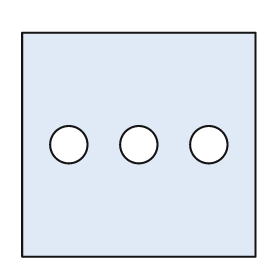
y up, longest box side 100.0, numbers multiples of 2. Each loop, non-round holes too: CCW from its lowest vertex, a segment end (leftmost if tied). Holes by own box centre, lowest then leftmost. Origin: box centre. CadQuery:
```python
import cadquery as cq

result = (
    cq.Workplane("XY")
    .moveTo(-50.0, -48.0)
    .lineTo(50.0, -48.0)
    .lineTo(50.0, 48.0)
    .lineTo(-50.0, 48.0)
    .close()
    .moveTo(-30.0, 0.0)
    .circle(8.0)
    .moveTo(0.0, 0.0)
    .circle(8.0)
    .moveTo(30.0, 0.0)
    .circle(8.0)
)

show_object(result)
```